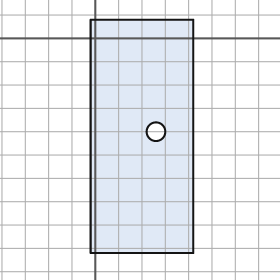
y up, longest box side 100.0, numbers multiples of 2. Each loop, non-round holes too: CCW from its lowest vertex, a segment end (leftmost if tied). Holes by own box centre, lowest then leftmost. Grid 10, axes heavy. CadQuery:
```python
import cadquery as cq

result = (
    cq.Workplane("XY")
    .moveTo(-2.0, -92.0)
    .lineTo(42.0, -92.0)
    .lineTo(42.0, 8.0)
    .lineTo(-2.0, 8.0)
    .close()
    .moveTo(26.0, -40.0)
    .circle(4.0)
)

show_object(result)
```